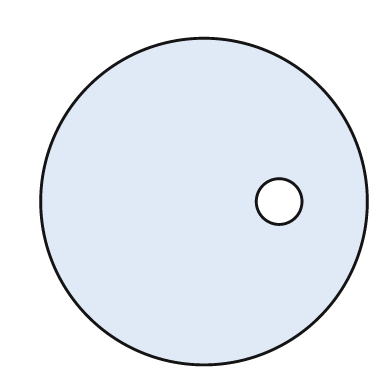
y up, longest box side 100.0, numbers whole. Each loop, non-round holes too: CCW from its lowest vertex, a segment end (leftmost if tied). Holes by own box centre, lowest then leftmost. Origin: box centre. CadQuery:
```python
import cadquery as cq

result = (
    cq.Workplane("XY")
    .moveTo(0.0, 0.0)
    .circle(50.0)
    .moveTo(23.0, 0.0)
    .circle(7.0)
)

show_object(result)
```